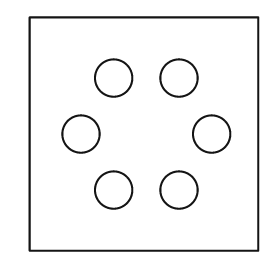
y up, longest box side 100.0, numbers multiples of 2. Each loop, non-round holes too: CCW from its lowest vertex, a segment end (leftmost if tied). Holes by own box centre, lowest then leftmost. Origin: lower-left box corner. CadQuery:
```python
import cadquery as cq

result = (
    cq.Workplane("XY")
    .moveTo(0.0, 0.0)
    .lineTo(98.0, 0.0)
    .lineTo(98.0, 100.0)
    .lineTo(0.0, 100.0)
    .close()
    .moveTo(36.0, 26.0)
    .circle(8.0)
    .moveTo(64.0, 26.0)
    .circle(8.0)
    .moveTo(22.0, 50.0)
    .circle(8.0)
    .moveTo(78.0, 50.0)
    .circle(8.0)
    .moveTo(36.0, 74.0)
    .circle(8.0)
    .moveTo(64.0, 74.0)
    .circle(8.0)
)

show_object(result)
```